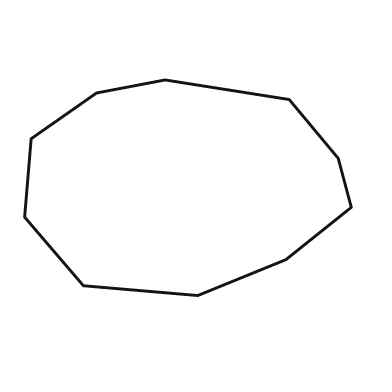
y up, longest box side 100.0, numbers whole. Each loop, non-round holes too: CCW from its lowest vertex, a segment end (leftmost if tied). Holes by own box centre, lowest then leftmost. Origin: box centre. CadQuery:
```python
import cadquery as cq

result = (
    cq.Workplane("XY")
    .moveTo(3.0, -33.0)
    .lineTo(30.0, -22.0)
    .lineTo(50.0, -6.0)
    .lineTo(46.0, 9.0)
    .lineTo(31.0, 27.0)
    .lineTo(-7.0, 33.0)
    .lineTo(-28.0, 29.0)
    .lineTo(-48.0, 15.0)
    .lineTo(-50.0, -9.0)
    .lineTo(-32.0, -30.0)
    .close()
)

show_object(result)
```